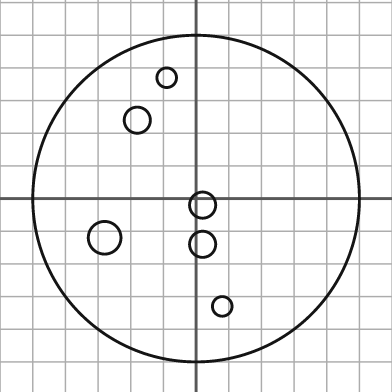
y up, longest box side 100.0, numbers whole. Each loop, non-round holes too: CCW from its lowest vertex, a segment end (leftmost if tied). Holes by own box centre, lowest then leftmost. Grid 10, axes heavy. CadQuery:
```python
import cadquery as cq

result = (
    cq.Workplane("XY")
    .moveTo(0.0, 0.0)
    .circle(50.0)
    .moveTo(8.0, -33.0)
    .circle(3.0)
    .moveTo(2.0, -14.0)
    .circle(4.0)
    .moveTo(-28.0, -12.0)
    .circle(5.0)
    .moveTo(2.0, -2.0)
    .circle(4.0)
    .moveTo(-18.0, 24.0)
    .circle(4.0)
    .moveTo(-9.0, 37.0)
    .circle(3.0)
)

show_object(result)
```